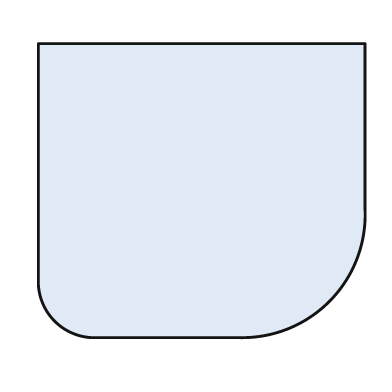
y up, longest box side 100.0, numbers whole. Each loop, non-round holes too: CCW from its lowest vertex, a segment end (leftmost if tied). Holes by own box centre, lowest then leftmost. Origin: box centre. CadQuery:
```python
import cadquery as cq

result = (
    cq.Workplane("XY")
    .moveTo(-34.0, -45.0)
    .lineTo(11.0, -45.0)
    .threePointArc((39.0, -34.0), (50.0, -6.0))
    .lineTo(50.0, 45.0)
    .lineTo(-50.0, 45.0)
    .lineTo(-50.0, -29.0)
    .threePointArc((-45.0, -40.0), (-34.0, -45.0))
    .close()
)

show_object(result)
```